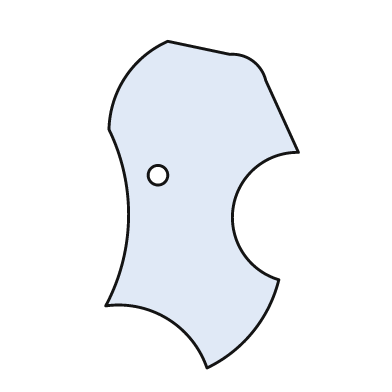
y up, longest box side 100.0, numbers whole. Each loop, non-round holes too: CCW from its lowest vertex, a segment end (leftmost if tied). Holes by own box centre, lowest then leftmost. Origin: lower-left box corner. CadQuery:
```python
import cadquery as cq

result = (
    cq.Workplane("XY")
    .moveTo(31.0, 0.0)
    .threePointArc((45.0, 11.0), (53.0, 27.0))
    .threePointArc((39.0, 49.0), (59.0, 66.0))
    .lineTo(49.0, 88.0)
    .threePointArc((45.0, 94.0), (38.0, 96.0))
    .lineTo(19.0, 100.0)
    .threePointArc((6.0, 89.0), (1.0, 73.0))
    .threePointArc((7.0, 46.0), (0.0, 19.0))
    .threePointArc((19.0, 15.0), (31.0, 0.0))
    .close()
    .moveTo(16.0, 59.0)
    .circle(3.0)
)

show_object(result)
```